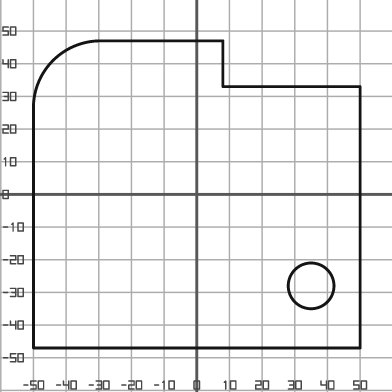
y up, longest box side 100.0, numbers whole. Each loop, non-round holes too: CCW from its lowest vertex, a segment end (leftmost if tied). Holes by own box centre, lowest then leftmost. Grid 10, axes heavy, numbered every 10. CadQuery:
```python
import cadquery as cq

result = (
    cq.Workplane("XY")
    .moveTo(-50.0, -47.0)
    .lineTo(50.0, -47.0)
    .lineTo(50.0, 33.0)
    .lineTo(8.0, 33.0)
    .lineTo(8.0, 47.0)
    .lineTo(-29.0, 47.0)
    .threePointArc((-44.0, 41.0), (-50.0, 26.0))
    .close()
    .moveTo(35.0, -28.0)
    .circle(7.0)
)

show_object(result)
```